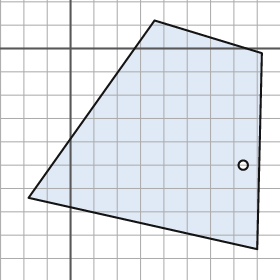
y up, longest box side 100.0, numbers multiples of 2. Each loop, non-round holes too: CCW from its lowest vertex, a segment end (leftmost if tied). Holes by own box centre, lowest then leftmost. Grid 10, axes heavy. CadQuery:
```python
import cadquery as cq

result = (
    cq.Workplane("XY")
    .moveTo(80.0, -86.0)
    .lineTo(82.0, -2.0)
    .lineTo(36.0, 12.0)
    .lineTo(-18.0, -64.0)
    .close()
    .moveTo(74.0, -50.0)
    .circle(2.0)
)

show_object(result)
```